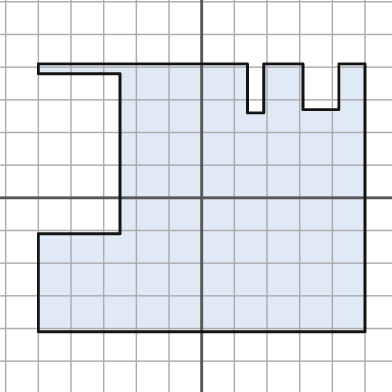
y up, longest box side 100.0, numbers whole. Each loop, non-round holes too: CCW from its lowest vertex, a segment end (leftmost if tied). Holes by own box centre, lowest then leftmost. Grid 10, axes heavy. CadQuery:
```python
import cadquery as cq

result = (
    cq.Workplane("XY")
    .moveTo(-50.0, -41.0)
    .lineTo(50.0, -41.0)
    .lineTo(50.0, 41.0)
    .lineTo(42.0, 41.0)
    .lineTo(42.0, 27.0)
    .lineTo(31.0, 27.0)
    .lineTo(31.0, 41.0)
    .lineTo(19.0, 41.0)
    .lineTo(19.0, 26.0)
    .lineTo(14.0, 26.0)
    .lineTo(14.0, 41.0)
    .lineTo(-50.0, 41.0)
    .lineTo(-50.0, 38.0)
    .lineTo(-25.0, 38.0)
    .lineTo(-25.0, -11.0)
    .lineTo(-50.0, -11.0)
    .close()
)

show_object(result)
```